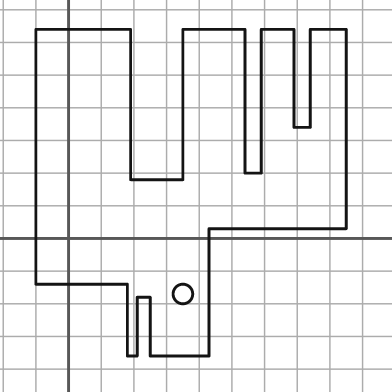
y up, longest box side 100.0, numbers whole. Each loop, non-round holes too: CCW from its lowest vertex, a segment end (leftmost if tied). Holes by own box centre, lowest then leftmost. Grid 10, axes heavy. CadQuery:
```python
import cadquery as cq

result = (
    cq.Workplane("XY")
    .moveTo(18.0, -36.0)
    .lineTo(21.0, -36.0)
    .lineTo(21.0, -18.0)
    .lineTo(25.0, -18.0)
    .lineTo(25.0, -36.0)
    .lineTo(43.0, -36.0)
    .lineTo(43.0, 3.0)
    .lineTo(85.0, 3.0)
    .lineTo(85.0, 64.0)
    .lineTo(74.0, 64.0)
    .lineTo(74.0, 34.0)
    .lineTo(69.0, 34.0)
    .lineTo(69.0, 64.0)
    .lineTo(59.0, 64.0)
    .lineTo(59.0, 20.0)
    .lineTo(54.0, 20.0)
    .lineTo(54.0, 64.0)
    .lineTo(35.0, 64.0)
    .lineTo(35.0, 18.0)
    .lineTo(19.0, 18.0)
    .lineTo(19.0, 64.0)
    .lineTo(-10.0, 64.0)
    .lineTo(-10.0, -14.0)
    .lineTo(18.0, -14.0)
    .close()
    .moveTo(35.0, -17.0)
    .circle(3.0)
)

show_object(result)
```